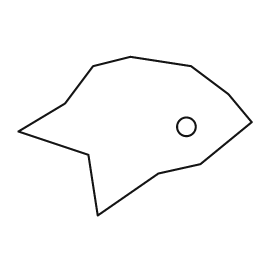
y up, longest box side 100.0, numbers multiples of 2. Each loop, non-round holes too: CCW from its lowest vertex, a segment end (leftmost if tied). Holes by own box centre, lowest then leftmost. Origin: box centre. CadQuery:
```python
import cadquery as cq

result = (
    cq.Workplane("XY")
    .moveTo(-16.0, -34.0)
    .lineTo(10.0, -16.0)
    .lineTo(28.0, -12.0)
    .lineTo(50.0, 6.0)
    .lineTo(40.0, 18.0)
    .lineTo(24.0, 30.0)
    .lineTo(-2.0, 34.0)
    .lineTo(-18.0, 30.0)
    .lineTo(-30.0, 14.0)
    .lineTo(-50.0, 2.0)
    .lineTo(-20.0, -8.0)
    .close()
    .moveTo(22.0, 4.0)
    .circle(4.0)
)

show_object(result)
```